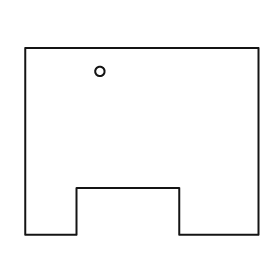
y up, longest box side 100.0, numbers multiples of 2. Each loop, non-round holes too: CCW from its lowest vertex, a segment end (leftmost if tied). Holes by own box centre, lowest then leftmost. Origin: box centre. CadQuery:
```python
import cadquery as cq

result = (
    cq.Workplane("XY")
    .moveTo(-50.0, -40.0)
    .lineTo(-28.0, -40.0)
    .lineTo(-28.0, -20.0)
    .lineTo(16.0, -20.0)
    .lineTo(16.0, -40.0)
    .lineTo(50.0, -40.0)
    .lineTo(50.0, 40.0)
    .lineTo(-50.0, 40.0)
    .close()
    .moveTo(-18.0, 30.0)
    .circle(2.0)
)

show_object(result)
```